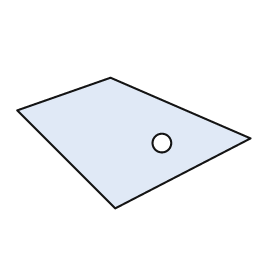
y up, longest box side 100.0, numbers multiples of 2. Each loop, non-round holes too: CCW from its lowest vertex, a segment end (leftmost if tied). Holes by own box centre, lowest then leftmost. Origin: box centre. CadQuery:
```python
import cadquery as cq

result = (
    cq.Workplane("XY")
    .moveTo(-8.0, -28.0)
    .lineTo(50.0, 2.0)
    .lineTo(-10.0, 28.0)
    .lineTo(-50.0, 14.0)
    .close()
    .moveTo(12.0, 0.0)
    .circle(4.0)
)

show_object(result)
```